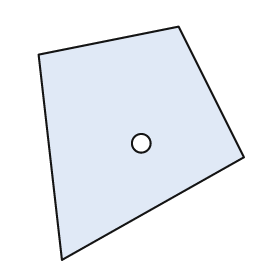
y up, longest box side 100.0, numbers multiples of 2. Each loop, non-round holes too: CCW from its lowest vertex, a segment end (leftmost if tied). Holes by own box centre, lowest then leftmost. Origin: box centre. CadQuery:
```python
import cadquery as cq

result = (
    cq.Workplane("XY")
    .moveTo(-34.0, -50.0)
    .lineTo(44.0, -6.0)
    .lineTo(16.0, 50.0)
    .lineTo(-44.0, 38.0)
    .close()
    .moveTo(0.0, 0.0)
    .circle(4.0)
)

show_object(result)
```